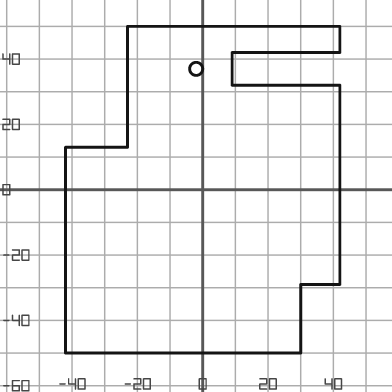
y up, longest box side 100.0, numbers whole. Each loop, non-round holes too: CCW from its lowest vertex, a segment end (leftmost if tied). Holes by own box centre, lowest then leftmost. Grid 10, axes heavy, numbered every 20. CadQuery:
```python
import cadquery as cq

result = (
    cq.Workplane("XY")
    .moveTo(-42.0, -50.0)
    .lineTo(30.0, -50.0)
    .lineTo(30.0, -29.0)
    .lineTo(42.0, -29.0)
    .lineTo(42.0, 32.0)
    .lineTo(9.0, 32.0)
    .lineTo(9.0, 42.0)
    .lineTo(42.0, 42.0)
    .lineTo(42.0, 50.0)
    .lineTo(-23.0, 50.0)
    .lineTo(-23.0, 13.0)
    .lineTo(-42.0, 13.0)
    .close()
    .moveTo(-2.0, 37.0)
    .circle(2.0)
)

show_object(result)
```